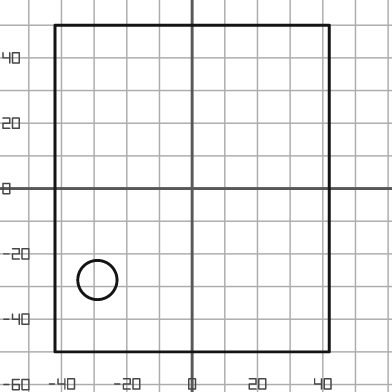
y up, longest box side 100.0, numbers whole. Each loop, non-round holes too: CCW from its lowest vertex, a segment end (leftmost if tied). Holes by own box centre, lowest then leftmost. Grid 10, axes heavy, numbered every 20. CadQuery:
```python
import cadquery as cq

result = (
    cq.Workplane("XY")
    .moveTo(-42.0, -50.0)
    .lineTo(42.0, -50.0)
    .lineTo(42.0, 50.0)
    .lineTo(-42.0, 50.0)
    .close()
    .moveTo(-29.0, -28.0)
    .circle(6.0)
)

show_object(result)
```